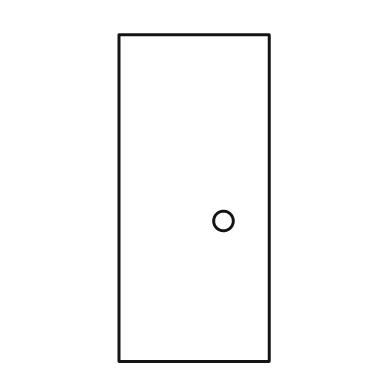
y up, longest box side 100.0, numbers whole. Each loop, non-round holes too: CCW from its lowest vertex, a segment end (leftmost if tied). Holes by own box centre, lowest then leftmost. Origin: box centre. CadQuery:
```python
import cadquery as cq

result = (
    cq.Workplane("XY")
    .moveTo(-23.0, -50.0)
    .lineTo(23.0, -50.0)
    .lineTo(23.0, 50.0)
    .lineTo(-23.0, 50.0)
    .close()
    .moveTo(9.0, -7.0)
    .circle(3.0)
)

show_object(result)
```